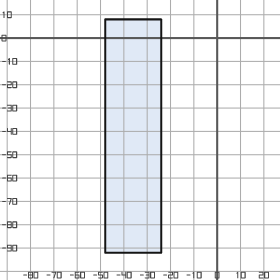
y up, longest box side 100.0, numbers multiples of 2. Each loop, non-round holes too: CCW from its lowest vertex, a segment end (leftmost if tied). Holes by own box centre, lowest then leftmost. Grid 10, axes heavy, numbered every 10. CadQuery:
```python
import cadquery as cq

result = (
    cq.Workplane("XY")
    .moveTo(-48.0, -92.0)
    .lineTo(-24.0, -92.0)
    .lineTo(-24.0, 8.0)
    .lineTo(-48.0, 8.0)
    .close()
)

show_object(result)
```